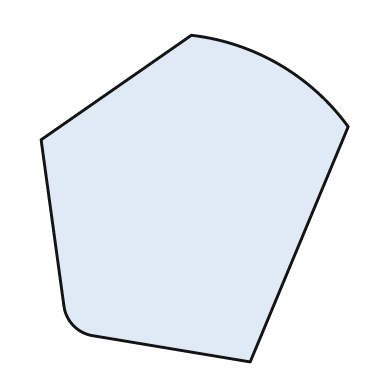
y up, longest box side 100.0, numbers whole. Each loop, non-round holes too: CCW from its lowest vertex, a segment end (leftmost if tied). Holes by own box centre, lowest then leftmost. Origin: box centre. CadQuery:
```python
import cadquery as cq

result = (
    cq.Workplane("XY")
    .moveTo(17.0, -50.0)
    .lineTo(47.0, 22.0)
    .threePointArc((26.0, 41.0), (-1.0, 50.0))
    .lineTo(-47.0, 18.0)
    .lineTo(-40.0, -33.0)
    .threePointArc((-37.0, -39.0), (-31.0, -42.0))
    .close()
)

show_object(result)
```